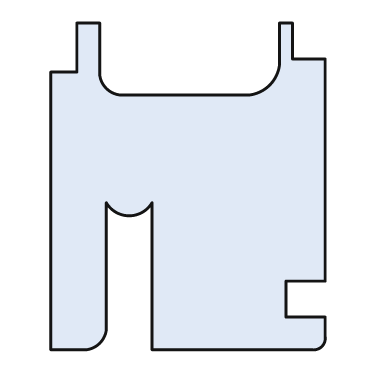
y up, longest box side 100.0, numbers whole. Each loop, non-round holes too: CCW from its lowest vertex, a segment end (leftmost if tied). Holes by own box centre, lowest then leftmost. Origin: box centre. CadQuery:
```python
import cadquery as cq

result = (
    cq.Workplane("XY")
    .moveTo(-42.0, -50.0)
    .lineTo(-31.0, -50.0)
    .threePointArc((-27.0, -48.0), (-25.0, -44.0))
    .lineTo(-25.0, -5.0)
    .threePointArc((-18.0, -9.0), (-11.0, -5.0))
    .lineTo(-11.0, -50.0)
    .lineTo(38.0, -50.0)
    .threePointArc((41.0, -49.0), (42.0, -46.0))
    .lineTo(42.0, -40.0)
    .lineTo(30.0, -40.0)
    .lineTo(30.0, -29.0)
    .lineTo(42.0, -29.0)
    .lineTo(42.0, 39.0)
    .lineTo(32.0, 39.0)
    .lineTo(32.0, 50.0)
    .lineTo(28.0, 50.0)
    .lineTo(28.0, 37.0)
    .threePointArc((25.0, 31.0), (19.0, 28.0))
    .lineTo(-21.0, 28.0)
    .threePointArc((-25.0, 30.0), (-27.0, 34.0))
    .lineTo(-27.0, 50.0)
    .lineTo(-34.0, 50.0)
    .lineTo(-34.0, 35.0)
    .lineTo(-42.0, 35.0)
    .close()
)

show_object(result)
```